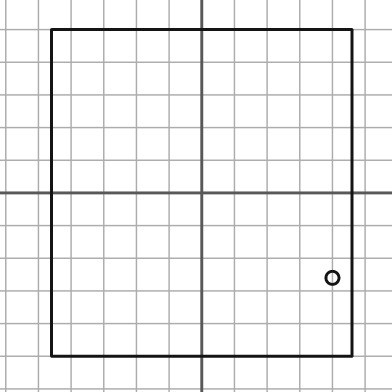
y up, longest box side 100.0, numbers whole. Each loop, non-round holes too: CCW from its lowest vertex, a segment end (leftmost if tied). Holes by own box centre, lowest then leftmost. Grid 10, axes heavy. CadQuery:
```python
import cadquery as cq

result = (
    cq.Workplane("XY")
    .moveTo(-46.0, -50.0)
    .lineTo(46.0, -50.0)
    .lineTo(46.0, 50.0)
    .lineTo(-46.0, 50.0)
    .close()
    .moveTo(40.0, -26.0)
    .circle(2.0)
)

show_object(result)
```